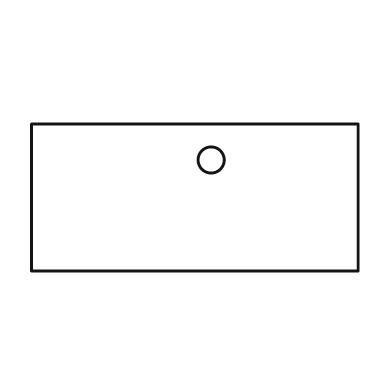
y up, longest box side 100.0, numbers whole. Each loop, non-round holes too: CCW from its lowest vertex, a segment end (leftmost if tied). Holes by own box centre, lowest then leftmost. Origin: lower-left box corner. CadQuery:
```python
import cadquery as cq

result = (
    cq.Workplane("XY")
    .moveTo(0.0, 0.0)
    .lineTo(100.0, 0.0)
    .lineTo(100.0, 45.0)
    .lineTo(0.0, 45.0)
    .close()
    .moveTo(55.0, 34.0)
    .circle(4.0)
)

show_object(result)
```